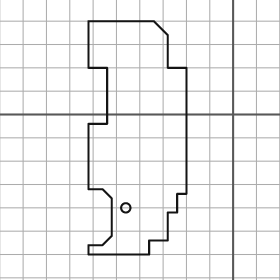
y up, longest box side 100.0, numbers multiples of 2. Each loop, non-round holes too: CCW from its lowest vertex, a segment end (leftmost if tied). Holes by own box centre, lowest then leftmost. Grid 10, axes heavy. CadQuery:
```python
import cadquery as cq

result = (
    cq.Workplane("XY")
    .moveTo(-62.0, -60.0)
    .lineTo(-36.0, -60.0)
    .lineTo(-36.0, -54.0)
    .lineTo(-28.0, -54.0)
    .lineTo(-28.0, -42.0)
    .lineTo(-24.0, -42.0)
    .lineTo(-24.0, -34.0)
    .lineTo(-20.0, -34.0)
    .lineTo(-20.0, 20.0)
    .lineTo(-28.0, 20.0)
    .lineTo(-28.0, 34.0)
    .lineTo(-34.0, 40.0)
    .lineTo(-62.0, 40.0)
    .lineTo(-62.0, 20.0)
    .lineTo(-54.0, 20.0)
    .lineTo(-54.0, -4.0)
    .lineTo(-62.0, -4.0)
    .lineTo(-62.0, -32.0)
    .lineTo(-56.0, -32.0)
    .lineTo(-52.0, -36.0)
    .lineTo(-52.0, -52.0)
    .lineTo(-56.0, -56.0)
    .lineTo(-62.0, -56.0)
    .close()
    .moveTo(-46.0, -40.0)
    .circle(2.0)
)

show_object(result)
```